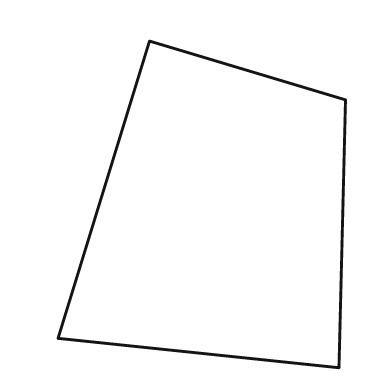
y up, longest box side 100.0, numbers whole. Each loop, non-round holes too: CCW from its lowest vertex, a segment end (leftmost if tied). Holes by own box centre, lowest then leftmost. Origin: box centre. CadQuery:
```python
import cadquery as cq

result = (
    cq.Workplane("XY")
    .moveTo(42.0, -50.0)
    .lineTo(44.0, 32.0)
    .lineTo(-16.0, 50.0)
    .lineTo(-44.0, -41.0)
    .close()
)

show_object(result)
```